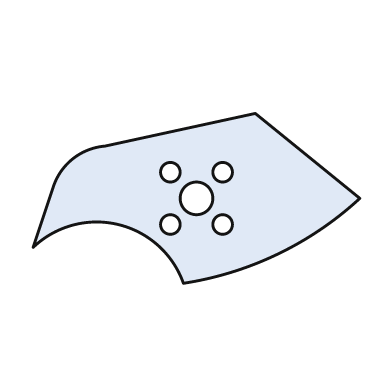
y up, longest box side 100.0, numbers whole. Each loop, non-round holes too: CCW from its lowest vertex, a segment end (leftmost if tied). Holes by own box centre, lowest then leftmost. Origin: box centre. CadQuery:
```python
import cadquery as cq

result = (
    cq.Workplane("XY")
    .moveTo(-4.0, -26.0)
    .threePointArc((25.0, -17.0), (50.0, 0.0))
    .lineTo(18.0, 26.0)
    .lineTo(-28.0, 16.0)
    .threePointArc((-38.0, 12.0), (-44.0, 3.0))
    .lineTo(-50.0, -15.0)
    .threePointArc((-24.0, -8.0), (-4.0, -26.0))
    .close()
    .moveTo(-8.0, -8.0)
    .circle(3.0)
    .moveTo(8.0, -8.0)
    .circle(3.0)
    .moveTo(0.0, 0.0)
    .circle(5.0)
    .moveTo(-8.0, 8.0)
    .circle(3.0)
    .moveTo(8.0, 8.0)
    .circle(3.0)
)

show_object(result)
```